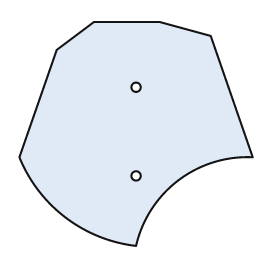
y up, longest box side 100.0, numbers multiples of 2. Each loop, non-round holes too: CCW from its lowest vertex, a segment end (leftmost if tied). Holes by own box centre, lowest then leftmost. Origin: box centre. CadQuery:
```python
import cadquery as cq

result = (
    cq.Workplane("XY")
    .moveTo(0.0, -48.0)
    .threePointArc((18.0, -20.0), (50.0, -10.0))
    .lineTo(32.0, 42.0)
    .lineTo(10.0, 48.0)
    .lineTo(-18.0, 48.0)
    .lineTo(-34.0, 36.0)
    .lineTo(-50.0, -10.0)
    .threePointArc((-30.0, -36.0), (0.0, -48.0))
    .close()
    .moveTo(0.0, -18.0)
    .circle(2.0)
    .moveTo(0.0, 20.0)
    .circle(2.0)
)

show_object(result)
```